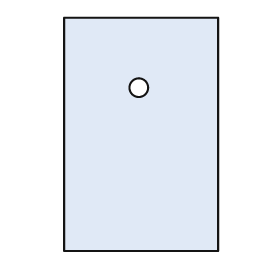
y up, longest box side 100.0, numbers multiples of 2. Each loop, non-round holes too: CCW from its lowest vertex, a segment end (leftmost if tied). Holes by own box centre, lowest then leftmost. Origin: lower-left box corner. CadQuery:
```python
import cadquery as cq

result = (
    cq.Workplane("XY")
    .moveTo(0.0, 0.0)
    .lineTo(66.0, 0.0)
    .lineTo(66.0, 100.0)
    .lineTo(0.0, 100.0)
    .close()
    .moveTo(32.0, 70.0)
    .circle(4.0)
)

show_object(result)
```